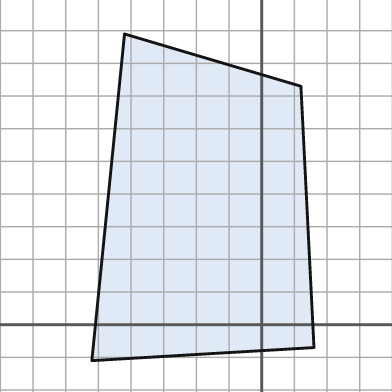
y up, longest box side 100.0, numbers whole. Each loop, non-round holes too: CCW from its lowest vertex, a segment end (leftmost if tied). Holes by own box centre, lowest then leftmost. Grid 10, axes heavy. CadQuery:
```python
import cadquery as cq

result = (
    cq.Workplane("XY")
    .moveTo(-52.0, -11.0)
    .lineTo(16.0, -7.0)
    .lineTo(12.0, 73.0)
    .lineTo(-42.0, 89.0)
    .close()
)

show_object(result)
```